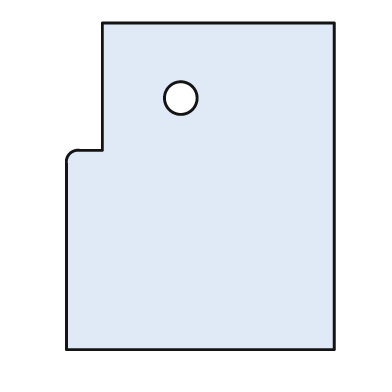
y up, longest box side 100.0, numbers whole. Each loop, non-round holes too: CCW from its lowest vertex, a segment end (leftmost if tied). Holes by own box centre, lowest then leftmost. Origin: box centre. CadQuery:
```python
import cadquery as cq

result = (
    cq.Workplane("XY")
    .moveTo(-41.0, -50.0)
    .lineTo(41.0, -50.0)
    .lineTo(41.0, 50.0)
    .lineTo(-30.0, 50.0)
    .lineTo(-30.0, 11.0)
    .lineTo(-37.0, 11.0)
    .threePointArc((-40.0, 10.0), (-41.0, 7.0))
    .close()
    .moveTo(-6.0, 27.0)
    .circle(5.0)
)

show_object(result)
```